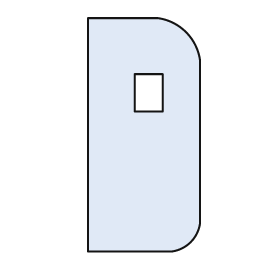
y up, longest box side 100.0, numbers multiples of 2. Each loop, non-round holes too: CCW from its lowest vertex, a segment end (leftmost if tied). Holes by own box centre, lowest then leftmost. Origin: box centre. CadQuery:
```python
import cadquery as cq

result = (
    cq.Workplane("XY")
    .moveTo(-24.0, -50.0)
    .lineTo(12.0, -50.0)
    .threePointArc((20.0, -46.0), (24.0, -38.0))
    .lineTo(24.0, 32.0)
    .threePointArc((18.0, 44.0), (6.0, 50.0))
    .lineTo(-24.0, 50.0)
    .close()
    .moveTo(-4.0, 10.0)
    .lineTo(8.0, 10.0)
    .lineTo(8.0, 26.0)
    .lineTo(-4.0, 26.0)
    .close()
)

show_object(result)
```